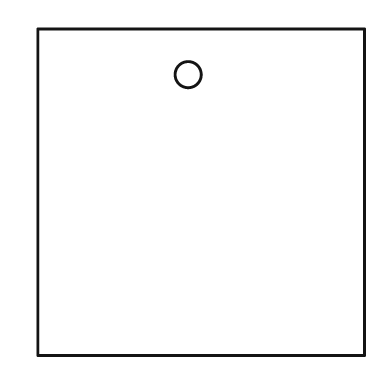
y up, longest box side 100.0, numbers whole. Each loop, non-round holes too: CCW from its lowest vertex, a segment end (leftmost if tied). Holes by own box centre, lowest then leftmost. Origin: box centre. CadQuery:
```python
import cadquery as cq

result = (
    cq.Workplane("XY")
    .moveTo(-50.0, -50.0)
    .lineTo(50.0, -50.0)
    .lineTo(50.0, 50.0)
    .lineTo(-50.0, 50.0)
    .close()
    .moveTo(-4.0, 36.0)
    .circle(4.0)
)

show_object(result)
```